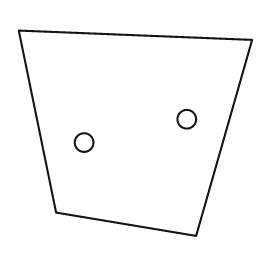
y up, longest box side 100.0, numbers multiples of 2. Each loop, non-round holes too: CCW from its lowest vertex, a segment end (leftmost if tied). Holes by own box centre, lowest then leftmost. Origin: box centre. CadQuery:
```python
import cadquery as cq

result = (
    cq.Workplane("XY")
    .moveTo(26.0, -44.0)
    .lineTo(50.0, 40.0)
    .lineTo(-50.0, 44.0)
    .lineTo(-34.0, -34.0)
    .close()
    .moveTo(-22.0, -4.0)
    .circle(4.0)
    .moveTo(22.0, 6.0)
    .circle(4.0)
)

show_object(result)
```